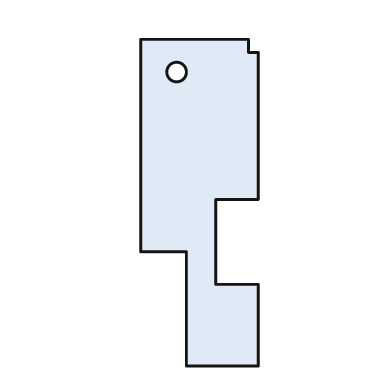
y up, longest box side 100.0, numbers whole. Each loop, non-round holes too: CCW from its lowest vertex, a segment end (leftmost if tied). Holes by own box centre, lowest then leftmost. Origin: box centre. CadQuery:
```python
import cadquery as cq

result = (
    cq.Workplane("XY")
    .moveTo(-4.0, -50.0)
    .lineTo(18.0, -50.0)
    .lineTo(18.0, -25.0)
    .lineTo(5.0, -25.0)
    .lineTo(5.0, 1.0)
    .lineTo(18.0, 1.0)
    .lineTo(18.0, 46.0)
    .lineTo(15.0, 46.0)
    .lineTo(15.0, 50.0)
    .lineTo(-18.0, 50.0)
    .lineTo(-18.0, -15.0)
    .lineTo(-4.0, -15.0)
    .close()
    .moveTo(-7.0, 40.0)
    .circle(3.0)
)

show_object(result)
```